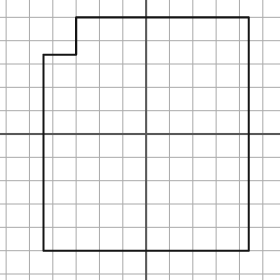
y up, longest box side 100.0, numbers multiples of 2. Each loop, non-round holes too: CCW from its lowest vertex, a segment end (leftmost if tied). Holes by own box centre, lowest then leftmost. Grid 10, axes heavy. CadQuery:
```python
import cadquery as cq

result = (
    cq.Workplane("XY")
    .moveTo(-44.0, -50.0)
    .lineTo(44.0, -50.0)
    .lineTo(44.0, 50.0)
    .lineTo(-30.0, 50.0)
    .lineTo(-30.0, 34.0)
    .lineTo(-44.0, 34.0)
    .close()
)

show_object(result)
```